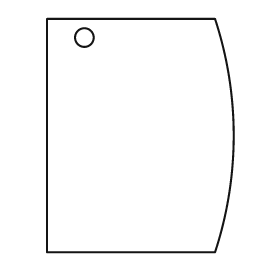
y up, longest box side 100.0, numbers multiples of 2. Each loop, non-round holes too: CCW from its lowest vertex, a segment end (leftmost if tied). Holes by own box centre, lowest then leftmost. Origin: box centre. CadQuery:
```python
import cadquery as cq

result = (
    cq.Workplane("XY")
    .moveTo(-40.0, -50.0)
    .lineTo(32.0, -50.0)
    .threePointArc((40.0, 0.0), (32.0, 50.0))
    .lineTo(-40.0, 50.0)
    .close()
    .moveTo(-24.0, 42.0)
    .circle(4.0)
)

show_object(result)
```